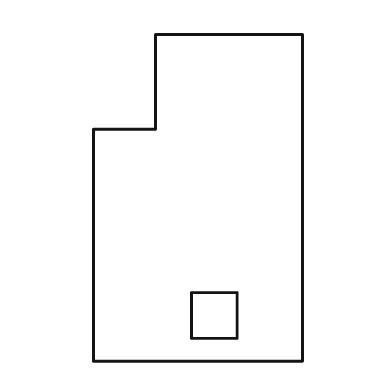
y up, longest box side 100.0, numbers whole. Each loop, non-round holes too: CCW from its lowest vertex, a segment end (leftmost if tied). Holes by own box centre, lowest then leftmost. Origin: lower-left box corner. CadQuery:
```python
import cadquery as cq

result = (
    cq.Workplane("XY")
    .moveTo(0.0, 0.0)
    .lineTo(64.0, 0.0)
    .lineTo(64.0, 100.0)
    .lineTo(19.0, 100.0)
    .lineTo(19.0, 71.0)
    .lineTo(0.0, 71.0)
    .close()
    .moveTo(30.0, 7.0)
    .lineTo(44.0, 7.0)
    .lineTo(44.0, 21.0)
    .lineTo(30.0, 21.0)
    .close()
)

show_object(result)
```